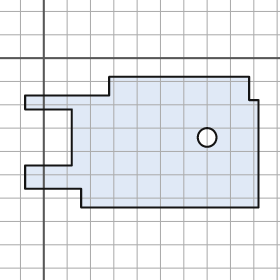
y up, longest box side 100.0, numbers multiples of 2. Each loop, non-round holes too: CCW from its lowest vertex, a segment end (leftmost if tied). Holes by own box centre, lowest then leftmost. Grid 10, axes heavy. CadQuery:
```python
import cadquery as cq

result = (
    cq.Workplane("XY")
    .moveTo(16.0, -64.0)
    .lineTo(92.0, -64.0)
    .lineTo(92.0, -18.0)
    .lineTo(88.0, -18.0)
    .lineTo(88.0, -8.0)
    .lineTo(28.0, -8.0)
    .lineTo(28.0, -16.0)
    .lineTo(-8.0, -16.0)
    .lineTo(-8.0, -22.0)
    .lineTo(12.0, -22.0)
    .lineTo(12.0, -46.0)
    .lineTo(-8.0, -46.0)
    .lineTo(-8.0, -56.0)
    .lineTo(16.0, -56.0)
    .close()
    .moveTo(70.0, -34.0)
    .circle(4.0)
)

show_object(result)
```